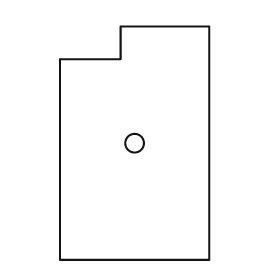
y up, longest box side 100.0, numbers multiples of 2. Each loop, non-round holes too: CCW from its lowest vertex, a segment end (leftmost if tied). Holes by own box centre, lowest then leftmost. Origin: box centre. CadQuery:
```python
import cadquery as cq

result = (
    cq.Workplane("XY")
    .moveTo(-32.0, -50.0)
    .lineTo(32.0, -50.0)
    .lineTo(32.0, 50.0)
    .lineTo(-6.0, 50.0)
    .lineTo(-6.0, 36.0)
    .lineTo(-32.0, 36.0)
    .close()
    .moveTo(0.0, 0.0)
    .circle(4.0)
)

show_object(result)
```